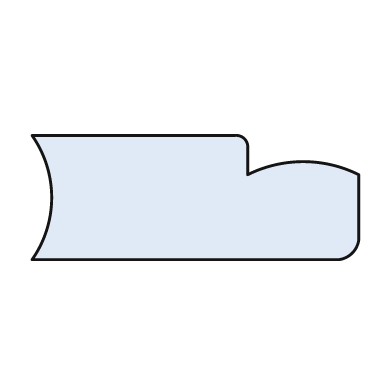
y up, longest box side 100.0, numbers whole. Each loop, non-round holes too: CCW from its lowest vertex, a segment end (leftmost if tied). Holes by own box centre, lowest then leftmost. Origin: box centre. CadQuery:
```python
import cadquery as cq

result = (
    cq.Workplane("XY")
    .moveTo(-50.0, -19.0)
    .lineTo(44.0, -19.0)
    .threePointArc((48.0, -17.0), (50.0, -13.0))
    .lineTo(50.0, 7.0)
    .threePointArc((33.0, 11.0), (16.0, 7.0))
    .lineTo(16.0, 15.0)
    .threePointArc((15.0, 18.0), (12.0, 19.0))
    .lineTo(-50.0, 19.0)
    .threePointArc((-44.0, 0.0), (-50.0, -19.0))
    .close()
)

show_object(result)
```